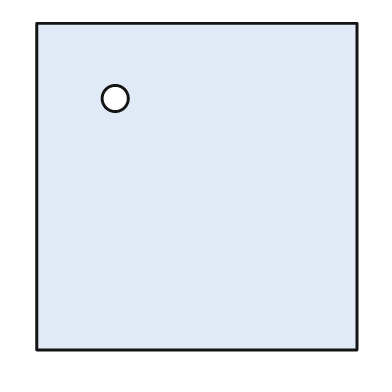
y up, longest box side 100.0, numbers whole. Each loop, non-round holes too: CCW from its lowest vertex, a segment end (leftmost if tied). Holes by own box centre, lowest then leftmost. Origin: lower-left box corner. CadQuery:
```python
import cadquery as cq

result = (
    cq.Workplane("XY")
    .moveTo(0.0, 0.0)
    .lineTo(98.0, 0.0)
    .lineTo(98.0, 100.0)
    .lineTo(0.0, 100.0)
    .close()
    .moveTo(24.0, 77.0)
    .circle(4.0)
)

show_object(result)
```